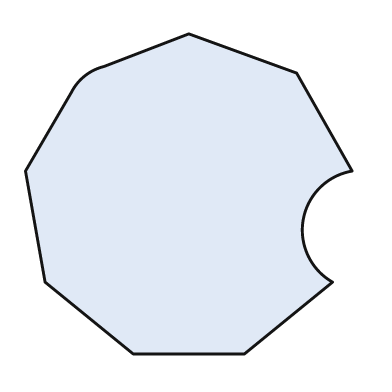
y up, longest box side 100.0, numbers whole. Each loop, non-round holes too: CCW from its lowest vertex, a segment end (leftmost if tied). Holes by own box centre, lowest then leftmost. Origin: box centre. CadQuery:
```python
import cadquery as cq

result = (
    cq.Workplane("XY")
    .moveTo(-17.0, -49.0)
    .lineTo(17.0, -49.0)
    .lineTo(44.0, -27.0)
    .threePointArc((35.0, -8.0), (50.0, 7.0))
    .lineTo(33.0, 37.0)
    .lineTo(0.0, 49.0)
    .lineTo(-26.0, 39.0)
    .threePointArc((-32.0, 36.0), (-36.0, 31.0))
    .lineTo(-50.0, 7.0)
    .lineTo(-44.0, -27.0)
    .close()
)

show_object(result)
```